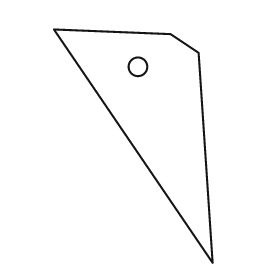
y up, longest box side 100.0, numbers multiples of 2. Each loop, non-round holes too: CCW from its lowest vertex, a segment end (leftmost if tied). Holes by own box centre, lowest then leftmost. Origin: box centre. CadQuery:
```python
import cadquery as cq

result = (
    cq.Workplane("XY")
    .moveTo(34.0, -50.0)
    .lineTo(28.0, 40.0)
    .lineTo(16.0, 48.0)
    .lineTo(-34.0, 50.0)
    .close()
    .moveTo(2.0, 34.0)
    .circle(4.0)
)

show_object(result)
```